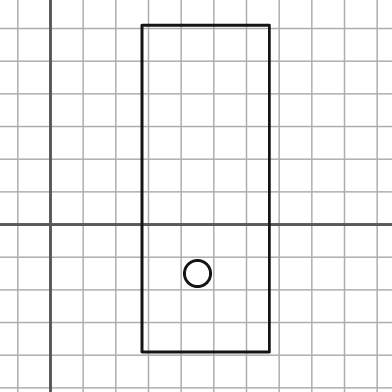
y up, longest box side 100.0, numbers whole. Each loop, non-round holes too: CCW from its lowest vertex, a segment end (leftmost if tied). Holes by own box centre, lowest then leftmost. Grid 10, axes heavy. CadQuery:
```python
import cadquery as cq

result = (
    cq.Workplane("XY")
    .moveTo(28.0, -39.0)
    .lineTo(67.0, -39.0)
    .lineTo(67.0, 61.0)
    .lineTo(28.0, 61.0)
    .close()
    .moveTo(45.0, -15.0)
    .circle(4.0)
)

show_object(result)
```